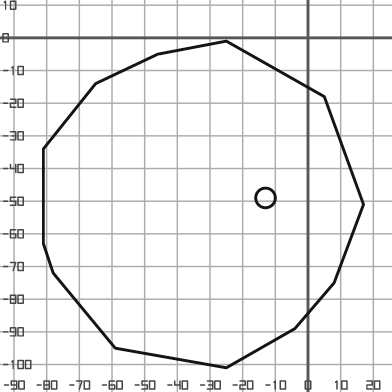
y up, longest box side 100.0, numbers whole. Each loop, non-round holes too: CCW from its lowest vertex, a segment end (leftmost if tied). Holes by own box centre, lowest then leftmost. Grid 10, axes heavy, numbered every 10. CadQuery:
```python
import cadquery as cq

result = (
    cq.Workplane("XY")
    .moveTo(-25.0, -101.0)
    .lineTo(-4.0, -89.0)
    .lineTo(8.0, -75.0)
    .lineTo(17.0, -51.0)
    .lineTo(5.0, -18.0)
    .lineTo(-25.0, -1.0)
    .lineTo(-46.0, -5.0)
    .lineTo(-65.0, -14.0)
    .lineTo(-81.0, -34.0)
    .lineTo(-81.0, -63.0)
    .lineTo(-78.0, -72.0)
    .lineTo(-59.0, -95.0)
    .close()
    .moveTo(-13.0, -49.0)
    .circle(3.0)
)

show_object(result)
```